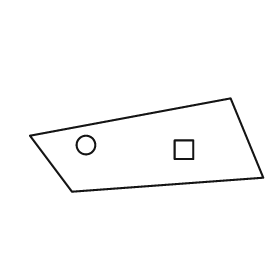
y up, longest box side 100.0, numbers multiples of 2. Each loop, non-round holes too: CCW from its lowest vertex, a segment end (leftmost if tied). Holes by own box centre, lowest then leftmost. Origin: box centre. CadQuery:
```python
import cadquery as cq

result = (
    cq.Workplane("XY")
    .moveTo(-32.0, -20.0)
    .lineTo(50.0, -14.0)
    .lineTo(36.0, 20.0)
    .lineTo(-50.0, 4.0)
    .close()
    .moveTo(12.0, -6.0)
    .lineTo(20.0, -6.0)
    .lineTo(20.0, 2.0)
    .lineTo(12.0, 2.0)
    .close()
    .moveTo(-26.0, 0.0)
    .circle(4.0)
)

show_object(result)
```